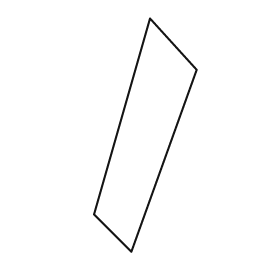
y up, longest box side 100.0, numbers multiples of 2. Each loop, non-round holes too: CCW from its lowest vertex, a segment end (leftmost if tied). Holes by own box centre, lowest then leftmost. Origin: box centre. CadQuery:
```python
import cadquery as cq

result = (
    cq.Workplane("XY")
    .moveTo(-6.0, -50.0)
    .lineTo(22.0, 28.0)
    .lineTo(2.0, 50.0)
    .lineTo(-22.0, -34.0)
    .close()
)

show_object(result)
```